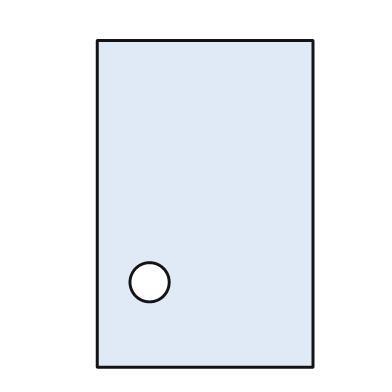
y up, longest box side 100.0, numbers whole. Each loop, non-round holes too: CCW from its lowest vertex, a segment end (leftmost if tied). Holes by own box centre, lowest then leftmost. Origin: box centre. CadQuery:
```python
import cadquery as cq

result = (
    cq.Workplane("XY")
    .moveTo(-33.0, -50.0)
    .lineTo(33.0, -50.0)
    .lineTo(33.0, 50.0)
    .lineTo(-33.0, 50.0)
    .close()
    .moveTo(-17.0, -24.0)
    .circle(6.0)
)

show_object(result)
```